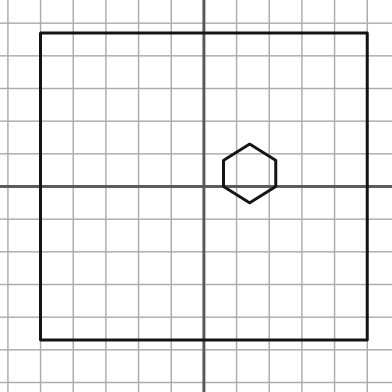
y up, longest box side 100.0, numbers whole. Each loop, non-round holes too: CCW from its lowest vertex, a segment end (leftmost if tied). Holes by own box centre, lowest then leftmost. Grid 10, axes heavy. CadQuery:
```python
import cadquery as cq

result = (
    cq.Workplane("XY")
    .moveTo(-50.0, -47.0)
    .lineTo(50.0, -47.0)
    .lineTo(50.0, 47.0)
    .lineTo(-50.0, 47.0)
    .close()
    .moveTo(14.0, -5.0)
    .lineTo(22.0, 0.0)
    .lineTo(22.0, 8.0)
    .lineTo(14.0, 13.0)
    .lineTo(6.0, 8.0)
    .lineTo(6.0, 0.0)
    .close()
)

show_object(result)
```